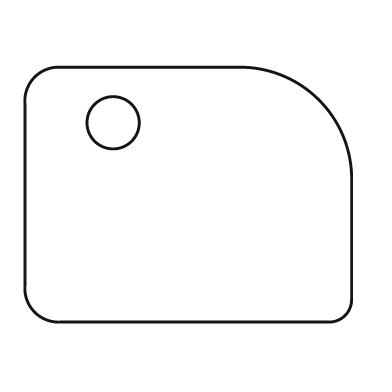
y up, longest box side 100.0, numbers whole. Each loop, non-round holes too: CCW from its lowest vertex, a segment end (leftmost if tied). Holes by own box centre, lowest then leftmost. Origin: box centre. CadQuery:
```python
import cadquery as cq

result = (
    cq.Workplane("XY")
    .moveTo(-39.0, -39.0)
    .lineTo(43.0, -39.0)
    .threePointArc((48.0, -37.0), (50.0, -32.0))
    .lineTo(50.0, 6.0)
    .threePointArc((40.0, 29.0), (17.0, 39.0))
    .lineTo(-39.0, 39.0)
    .threePointArc((-47.0, 36.0), (-50.0, 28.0))
    .lineTo(-50.0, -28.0)
    .threePointArc((-47.0, -36.0), (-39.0, -39.0))
    .close()
    .moveTo(-23.0, 22.0)
    .circle(8.0)
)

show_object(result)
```